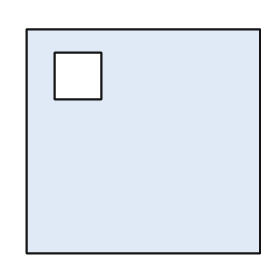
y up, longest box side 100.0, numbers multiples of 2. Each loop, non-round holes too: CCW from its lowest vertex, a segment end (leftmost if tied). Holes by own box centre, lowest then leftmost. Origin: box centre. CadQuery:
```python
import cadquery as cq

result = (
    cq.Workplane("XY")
    .moveTo(-50.0, -48.0)
    .lineTo(50.0, -48.0)
    .lineTo(50.0, 48.0)
    .lineTo(-50.0, 48.0)
    .close()
    .moveTo(-38.0, 18.0)
    .lineTo(-18.0, 18.0)
    .lineTo(-18.0, 38.0)
    .lineTo(-38.0, 38.0)
    .close()
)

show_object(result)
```